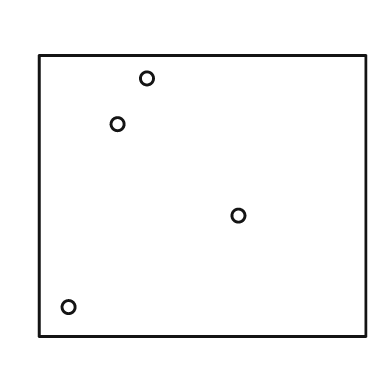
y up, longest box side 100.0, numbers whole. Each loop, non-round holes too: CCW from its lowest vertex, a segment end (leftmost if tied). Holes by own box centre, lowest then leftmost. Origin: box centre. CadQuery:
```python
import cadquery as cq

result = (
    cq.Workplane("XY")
    .moveTo(-50.0, -43.0)
    .lineTo(50.0, -43.0)
    .lineTo(50.0, 43.0)
    .lineTo(-50.0, 43.0)
    .close()
    .moveTo(-41.0, -34.0)
    .circle(2.0)
    .moveTo(11.0, -6.0)
    .circle(2.0)
    .moveTo(-26.0, 22.0)
    .circle(2.0)
    .moveTo(-17.0, 36.0)
    .circle(2.0)
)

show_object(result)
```